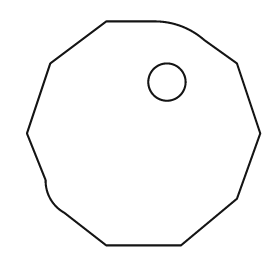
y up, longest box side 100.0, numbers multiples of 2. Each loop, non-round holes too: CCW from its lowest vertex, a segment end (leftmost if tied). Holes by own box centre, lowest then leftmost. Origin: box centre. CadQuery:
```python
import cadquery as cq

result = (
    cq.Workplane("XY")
    .moveTo(-16.0, -48.0)
    .lineTo(16.0, -48.0)
    .lineTo(40.0, -28.0)
    .lineTo(50.0, 0.0)
    .lineTo(40.0, 30.0)
    .lineTo(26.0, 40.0)
    .threePointArc((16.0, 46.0), (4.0, 48.0))
    .lineTo(-16.0, 48.0)
    .lineTo(-40.0, 30.0)
    .lineTo(-50.0, 0.0)
    .lineTo(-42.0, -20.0)
    .threePointArc((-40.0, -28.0), (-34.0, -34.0))
    .close()
    .moveTo(10.0, 22.0)
    .circle(8.0)
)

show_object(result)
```